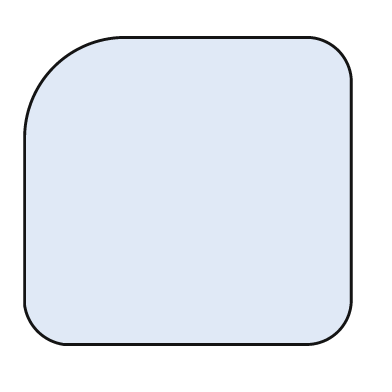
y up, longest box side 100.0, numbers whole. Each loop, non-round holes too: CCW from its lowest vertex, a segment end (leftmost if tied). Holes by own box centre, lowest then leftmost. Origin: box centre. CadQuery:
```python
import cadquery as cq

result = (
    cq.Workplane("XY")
    .moveTo(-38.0, -47.0)
    .lineTo(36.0, -47.0)
    .threePointArc((46.0, -43.0), (50.0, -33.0))
    .lineTo(50.0, 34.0)
    .threePointArc((46.0, 43.0), (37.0, 47.0))
    .lineTo(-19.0, 47.0)
    .threePointArc((-41.0, 38.0), (-50.0, 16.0))
    .lineTo(-50.0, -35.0)
    .threePointArc((-46.0, -43.0), (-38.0, -47.0))
    .close()
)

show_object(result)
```